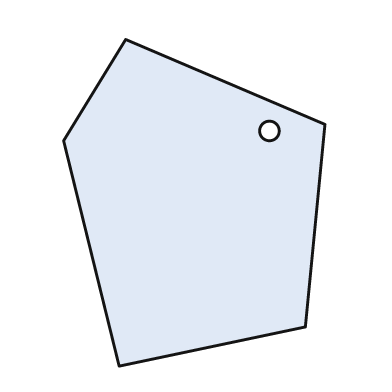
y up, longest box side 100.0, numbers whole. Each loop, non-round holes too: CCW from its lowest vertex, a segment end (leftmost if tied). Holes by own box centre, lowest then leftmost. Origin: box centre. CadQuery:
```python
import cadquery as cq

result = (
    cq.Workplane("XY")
    .moveTo(-23.0, -50.0)
    .lineTo(34.0, -38.0)
    .lineTo(40.0, 24.0)
    .lineTo(-21.0, 50.0)
    .lineTo(-40.0, 19.0)
    .close()
    .moveTo(23.0, 22.0)
    .circle(3.0)
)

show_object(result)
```